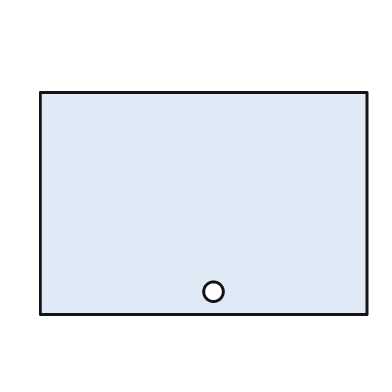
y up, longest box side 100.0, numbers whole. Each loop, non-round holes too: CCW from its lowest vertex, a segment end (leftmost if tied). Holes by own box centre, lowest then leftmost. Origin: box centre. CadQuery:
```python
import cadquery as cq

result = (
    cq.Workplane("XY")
    .moveTo(-50.0, -34.0)
    .lineTo(50.0, -34.0)
    .lineTo(50.0, 34.0)
    .lineTo(-50.0, 34.0)
    .close()
    .moveTo(3.0, -27.0)
    .circle(3.0)
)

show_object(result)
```